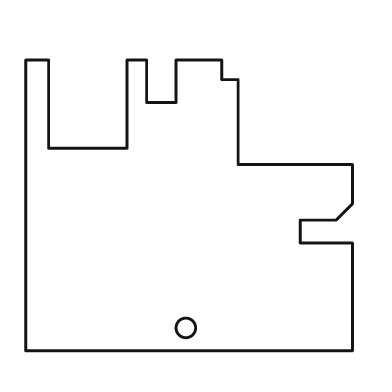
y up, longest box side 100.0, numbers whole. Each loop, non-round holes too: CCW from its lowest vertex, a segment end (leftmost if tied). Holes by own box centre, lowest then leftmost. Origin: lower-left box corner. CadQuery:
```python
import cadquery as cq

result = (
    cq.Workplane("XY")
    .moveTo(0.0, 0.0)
    .lineTo(100.0, 0.0)
    .lineTo(100.0, 33.0)
    .lineTo(84.0, 33.0)
    .lineTo(84.0, 40.0)
    .lineTo(95.0, 40.0)
    .lineTo(100.0, 45.0)
    .lineTo(100.0, 57.0)
    .lineTo(65.0, 57.0)
    .lineTo(65.0, 83.0)
    .lineTo(60.0, 83.0)
    .lineTo(60.0, 89.0)
    .lineTo(46.0, 89.0)
    .lineTo(46.0, 76.0)
    .lineTo(37.0, 76.0)
    .lineTo(37.0, 89.0)
    .lineTo(31.0, 89.0)
    .lineTo(31.0, 62.0)
    .lineTo(7.0, 62.0)
    .lineTo(7.0, 89.0)
    .lineTo(0.0, 89.0)
    .close()
    .moveTo(49.0, 7.0)
    .circle(3.0)
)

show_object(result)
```